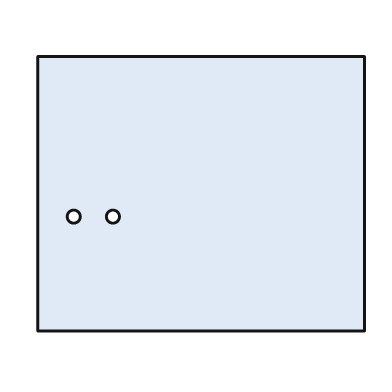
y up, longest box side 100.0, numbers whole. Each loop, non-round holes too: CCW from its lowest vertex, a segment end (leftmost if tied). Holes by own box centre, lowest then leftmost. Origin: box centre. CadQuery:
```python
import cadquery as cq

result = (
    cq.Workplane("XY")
    .moveTo(-50.0, -42.0)
    .lineTo(50.0, -42.0)
    .lineTo(50.0, 42.0)
    .lineTo(-50.0, 42.0)
    .close()
    .moveTo(-39.0, -7.0)
    .circle(2.0)
    .moveTo(-27.0, -7.0)
    .circle(2.0)
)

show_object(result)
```